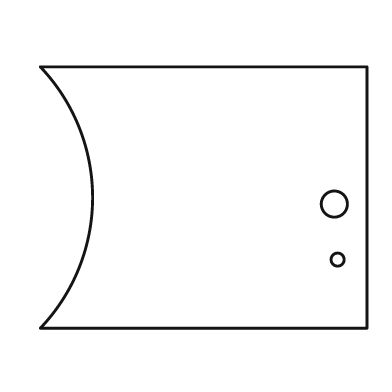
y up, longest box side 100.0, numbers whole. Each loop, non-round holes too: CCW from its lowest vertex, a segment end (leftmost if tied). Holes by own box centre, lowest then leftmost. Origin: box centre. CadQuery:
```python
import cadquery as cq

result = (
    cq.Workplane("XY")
    .moveTo(-50.0, -40.0)
    .lineTo(50.0, -40.0)
    .lineTo(50.0, 40.0)
    .lineTo(-50.0, 40.0)
    .threePointArc((-34.0, 0.0), (-50.0, -40.0))
    .close()
    .moveTo(41.0, -19.0)
    .circle(2.0)
    .moveTo(40.0, -2.0)
    .circle(4.0)
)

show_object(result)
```